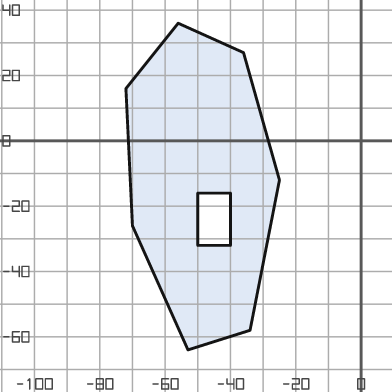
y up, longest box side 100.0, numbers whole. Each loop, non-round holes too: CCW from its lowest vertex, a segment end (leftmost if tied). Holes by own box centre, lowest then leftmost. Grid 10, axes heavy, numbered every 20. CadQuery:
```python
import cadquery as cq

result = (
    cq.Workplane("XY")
    .moveTo(-53.0, -64.0)
    .lineTo(-34.0, -58.0)
    .lineTo(-25.0, -12.0)
    .lineTo(-36.0, 27.0)
    .lineTo(-56.0, 36.0)
    .lineTo(-72.0, 16.0)
    .lineTo(-70.0, -26.0)
    .close()
    .moveTo(-50.0, -32.0)
    .lineTo(-40.0, -32.0)
    .lineTo(-40.0, -16.0)
    .lineTo(-50.0, -16.0)
    .close()
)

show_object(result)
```